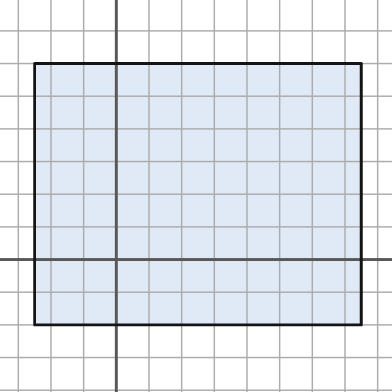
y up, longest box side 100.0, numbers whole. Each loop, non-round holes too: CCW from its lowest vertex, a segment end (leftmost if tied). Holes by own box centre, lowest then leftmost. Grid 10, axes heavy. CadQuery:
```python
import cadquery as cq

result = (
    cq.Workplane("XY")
    .moveTo(-25.0, -20.0)
    .lineTo(75.0, -20.0)
    .lineTo(75.0, 60.0)
    .lineTo(-25.0, 60.0)
    .close()
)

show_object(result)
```